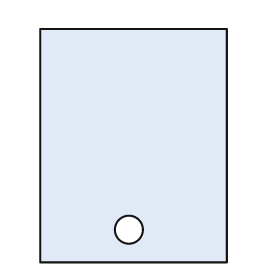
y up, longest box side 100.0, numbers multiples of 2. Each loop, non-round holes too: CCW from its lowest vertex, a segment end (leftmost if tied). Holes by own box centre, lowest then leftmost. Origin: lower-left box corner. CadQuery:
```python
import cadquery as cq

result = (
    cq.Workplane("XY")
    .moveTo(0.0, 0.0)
    .lineTo(80.0, 0.0)
    .lineTo(80.0, 100.0)
    .lineTo(0.0, 100.0)
    .close()
    .moveTo(38.0, 14.0)
    .circle(6.0)
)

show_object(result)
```